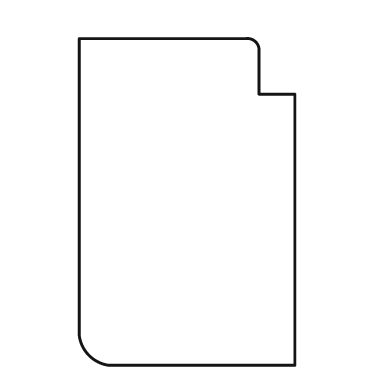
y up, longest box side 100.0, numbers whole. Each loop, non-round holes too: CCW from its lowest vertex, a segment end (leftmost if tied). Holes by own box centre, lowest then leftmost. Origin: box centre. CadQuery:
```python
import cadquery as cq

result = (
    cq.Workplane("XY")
    .moveTo(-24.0, -50.0)
    .lineTo(33.0, -50.0)
    .lineTo(33.0, 33.0)
    .lineTo(22.0, 33.0)
    .lineTo(22.0, 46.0)
    .threePointArc((21.0, 49.0), (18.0, 50.0))
    .lineTo(-33.0, 50.0)
    .lineTo(-33.0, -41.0)
    .threePointArc((-30.0, -47.0), (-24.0, -50.0))
    .close()
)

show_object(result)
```